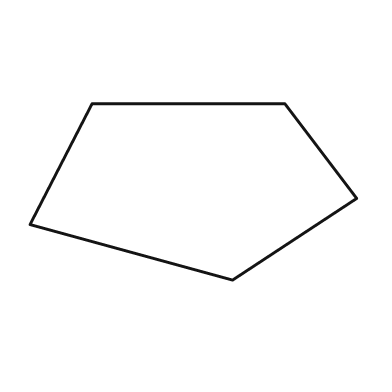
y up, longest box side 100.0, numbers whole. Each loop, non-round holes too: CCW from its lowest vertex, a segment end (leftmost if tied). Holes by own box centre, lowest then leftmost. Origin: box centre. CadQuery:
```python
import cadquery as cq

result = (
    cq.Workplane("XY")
    .moveTo(12.0, -27.0)
    .lineTo(50.0, -2.0)
    .lineTo(28.0, 27.0)
    .lineTo(-31.0, 27.0)
    .lineTo(-50.0, -10.0)
    .close()
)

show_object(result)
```